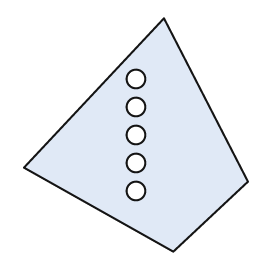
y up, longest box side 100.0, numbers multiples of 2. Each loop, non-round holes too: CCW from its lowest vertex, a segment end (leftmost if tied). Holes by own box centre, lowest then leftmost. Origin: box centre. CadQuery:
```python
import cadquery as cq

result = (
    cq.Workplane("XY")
    .moveTo(16.0, -50.0)
    .lineTo(48.0, -20.0)
    .lineTo(12.0, 50.0)
    .lineTo(-48.0, -14.0)
    .close()
    .moveTo(0.0, -24.0)
    .circle(4.0)
    .moveTo(0.0, -12.0)
    .circle(4.0)
    .moveTo(0.0, 0.0)
    .circle(4.0)
    .moveTo(0.0, 12.0)
    .circle(4.0)
    .moveTo(0.0, 24.0)
    .circle(4.0)
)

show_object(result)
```